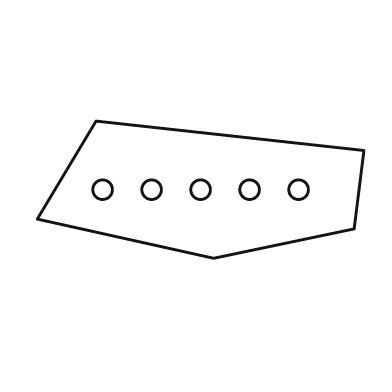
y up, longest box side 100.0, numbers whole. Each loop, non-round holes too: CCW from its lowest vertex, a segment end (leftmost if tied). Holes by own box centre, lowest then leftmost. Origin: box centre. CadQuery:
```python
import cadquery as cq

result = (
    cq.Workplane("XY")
    .moveTo(4.0, -21.0)
    .lineTo(47.0, -12.0)
    .lineTo(50.0, 12.0)
    .lineTo(-32.0, 21.0)
    .lineTo(-50.0, -9.0)
    .close()
    .moveTo(-30.0, 0.0)
    .circle(3.0)
    .moveTo(-15.0, 0.0)
    .circle(3.0)
    .moveTo(0.0, 0.0)
    .circle(3.0)
    .moveTo(15.0, 0.0)
    .circle(3.0)
    .moveTo(30.0, 0.0)
    .circle(3.0)
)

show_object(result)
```